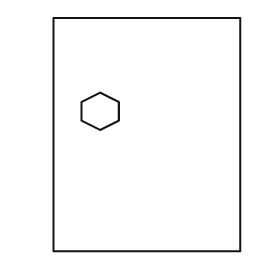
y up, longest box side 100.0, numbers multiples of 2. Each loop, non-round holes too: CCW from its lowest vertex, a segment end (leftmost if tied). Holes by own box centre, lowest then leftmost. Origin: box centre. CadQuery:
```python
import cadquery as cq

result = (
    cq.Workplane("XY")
    .moveTo(-40.0, -50.0)
    .lineTo(40.0, -50.0)
    .lineTo(40.0, 50.0)
    .lineTo(-40.0, 50.0)
    .close()
    .moveTo(-20.0, 2.0)
    .lineTo(-12.0, 6.0)
    .lineTo(-12.0, 14.0)
    .lineTo(-20.0, 18.0)
    .lineTo(-28.0, 14.0)
    .lineTo(-28.0, 6.0)
    .close()
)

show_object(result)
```